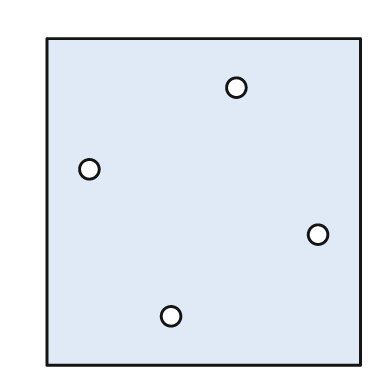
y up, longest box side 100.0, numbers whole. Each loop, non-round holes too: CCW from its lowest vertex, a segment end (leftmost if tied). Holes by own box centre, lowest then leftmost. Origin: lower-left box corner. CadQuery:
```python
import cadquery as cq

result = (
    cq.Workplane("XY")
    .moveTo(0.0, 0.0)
    .lineTo(96.0, 0.0)
    .lineTo(96.0, 100.0)
    .lineTo(0.0, 100.0)
    .close()
    .moveTo(38.0, 15.0)
    .circle(3.0)
    .moveTo(83.0, 40.0)
    .circle(3.0)
    .moveTo(13.0, 60.0)
    .circle(3.0)
    .moveTo(58.0, 85.0)
    .circle(3.0)
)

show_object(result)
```